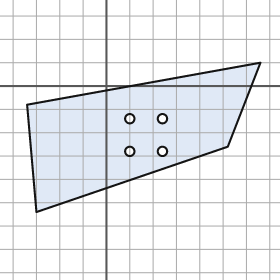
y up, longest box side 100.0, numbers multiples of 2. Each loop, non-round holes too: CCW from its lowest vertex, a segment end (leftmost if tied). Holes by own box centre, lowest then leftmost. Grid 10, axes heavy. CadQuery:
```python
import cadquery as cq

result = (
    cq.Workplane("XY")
    .moveTo(-30.0, -54.0)
    .lineTo(52.0, -26.0)
    .lineTo(66.0, 10.0)
    .lineTo(-34.0, -8.0)
    .close()
    .moveTo(10.0, -28.0)
    .circle(2.0)
    .moveTo(24.0, -28.0)
    .circle(2.0)
    .moveTo(10.0, -14.0)
    .circle(2.0)
    .moveTo(24.0, -14.0)
    .circle(2.0)
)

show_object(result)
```